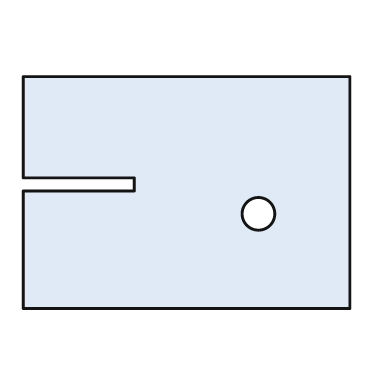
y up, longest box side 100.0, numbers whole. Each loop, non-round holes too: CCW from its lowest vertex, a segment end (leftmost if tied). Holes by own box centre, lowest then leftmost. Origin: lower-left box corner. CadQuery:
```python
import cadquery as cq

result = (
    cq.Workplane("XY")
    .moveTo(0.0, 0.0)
    .lineTo(100.0, 0.0)
    .lineTo(100.0, 71.0)
    .lineTo(0.0, 71.0)
    .lineTo(0.0, 40.0)
    .lineTo(34.0, 40.0)
    .lineTo(34.0, 36.0)
    .lineTo(0.0, 36.0)
    .close()
    .moveTo(72.0, 29.0)
    .circle(5.0)
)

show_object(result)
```